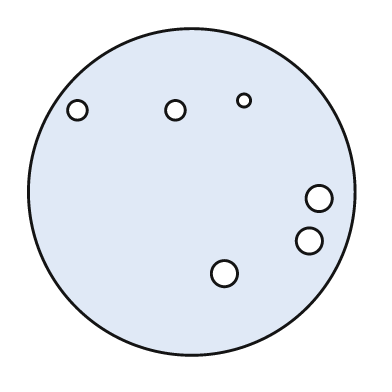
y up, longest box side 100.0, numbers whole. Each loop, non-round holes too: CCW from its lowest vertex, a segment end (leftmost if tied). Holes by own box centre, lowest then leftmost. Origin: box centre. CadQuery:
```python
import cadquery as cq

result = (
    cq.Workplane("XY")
    .moveTo(0.0, 0.0)
    .circle(50.0)
    .moveTo(10.0, -25.0)
    .circle(4.0)
    .moveTo(36.0, -15.0)
    .circle(4.0)
    .moveTo(39.0, -2.0)
    .circle(4.0)
    .moveTo(-35.0, 25.0)
    .circle(3.0)
    .moveTo(-5.0, 25.0)
    .circle(3.0)
    .moveTo(16.0, 28.0)
    .circle(2.0)
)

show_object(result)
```